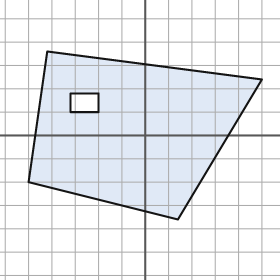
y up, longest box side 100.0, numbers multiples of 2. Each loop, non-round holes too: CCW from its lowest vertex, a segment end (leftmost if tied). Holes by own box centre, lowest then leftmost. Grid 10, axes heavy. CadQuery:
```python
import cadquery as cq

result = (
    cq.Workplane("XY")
    .moveTo(14.0, -36.0)
    .lineTo(50.0, 24.0)
    .lineTo(-42.0, 36.0)
    .lineTo(-50.0, -20.0)
    .close()
    .moveTo(-32.0, 10.0)
    .lineTo(-20.0, 10.0)
    .lineTo(-20.0, 18.0)
    .lineTo(-32.0, 18.0)
    .close()
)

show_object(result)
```